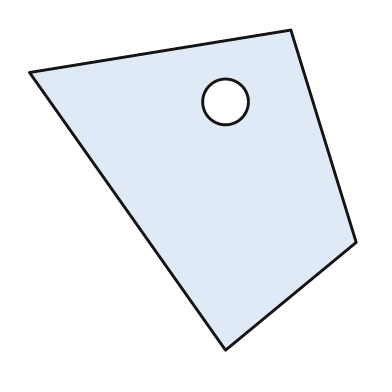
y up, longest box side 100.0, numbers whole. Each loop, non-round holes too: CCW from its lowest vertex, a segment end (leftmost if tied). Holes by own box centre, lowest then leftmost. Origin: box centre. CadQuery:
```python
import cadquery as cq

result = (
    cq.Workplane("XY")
    .moveTo(10.0, -49.0)
    .lineTo(50.0, -16.0)
    .lineTo(30.0, 49.0)
    .lineTo(-50.0, 36.0)
    .close()
    .moveTo(10.0, 27.0)
    .circle(7.0)
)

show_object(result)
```